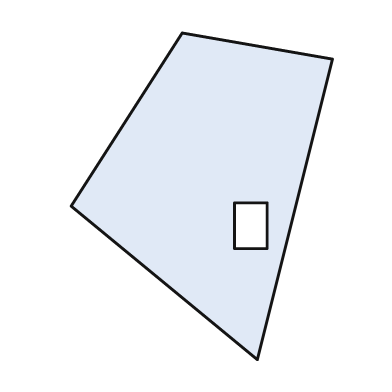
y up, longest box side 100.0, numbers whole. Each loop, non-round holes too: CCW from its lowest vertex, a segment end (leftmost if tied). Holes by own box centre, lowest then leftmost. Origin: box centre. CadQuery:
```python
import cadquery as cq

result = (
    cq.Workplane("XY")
    .moveTo(17.0, -50.0)
    .lineTo(40.0, 42.0)
    .lineTo(-6.0, 50.0)
    .lineTo(-40.0, -3.0)
    .close()
    .moveTo(10.0, -16.0)
    .lineTo(20.0, -16.0)
    .lineTo(20.0, -2.0)
    .lineTo(10.0, -2.0)
    .close()
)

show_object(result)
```